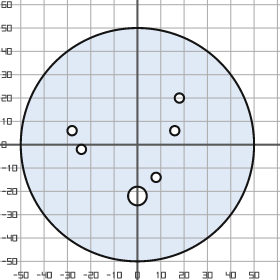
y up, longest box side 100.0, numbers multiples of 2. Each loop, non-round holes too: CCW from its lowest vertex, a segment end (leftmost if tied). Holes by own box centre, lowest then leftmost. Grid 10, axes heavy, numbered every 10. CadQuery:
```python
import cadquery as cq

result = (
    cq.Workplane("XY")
    .moveTo(0.0, 0.0)
    .circle(50.0)
    .moveTo(0.0, -22.0)
    .circle(4.0)
    .moveTo(8.0, -14.0)
    .circle(2.0)
    .moveTo(-24.0, -2.0)
    .circle(2.0)
    .moveTo(-28.0, 6.0)
    .circle(2.0)
    .moveTo(16.0, 6.0)
    .circle(2.0)
    .moveTo(18.0, 20.0)
    .circle(2.0)
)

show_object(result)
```